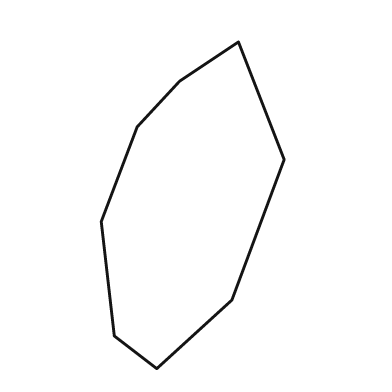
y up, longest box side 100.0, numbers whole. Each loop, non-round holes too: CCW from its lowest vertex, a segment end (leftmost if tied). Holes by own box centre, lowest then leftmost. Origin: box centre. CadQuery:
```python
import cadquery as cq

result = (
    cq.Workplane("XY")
    .moveTo(-11.0, -50.0)
    .lineTo(12.0, -29.0)
    .lineTo(28.0, 14.0)
    .lineTo(14.0, 50.0)
    .lineTo(-4.0, 38.0)
    .lineTo(-17.0, 24.0)
    .lineTo(-28.0, -5.0)
    .lineTo(-24.0, -40.0)
    .close()
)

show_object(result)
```